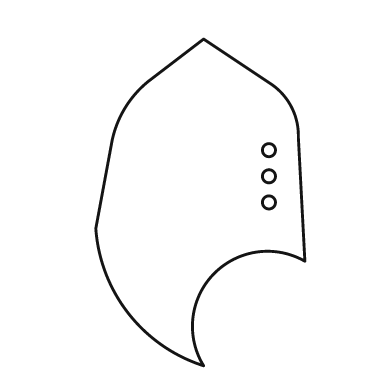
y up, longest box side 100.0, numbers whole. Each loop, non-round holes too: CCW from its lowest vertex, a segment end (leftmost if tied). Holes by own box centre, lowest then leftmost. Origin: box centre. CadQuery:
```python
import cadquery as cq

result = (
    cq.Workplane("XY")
    .moveTo(1.0, -50.0)
    .threePointArc((4.0, -22.0), (32.0, -18.0))
    .lineTo(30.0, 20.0)
    .threePointArc((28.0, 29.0), (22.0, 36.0))
    .lineTo(1.0, 50.0)
    .lineTo(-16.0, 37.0)
    .threePointArc((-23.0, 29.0), (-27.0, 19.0))
    .lineTo(-32.0, -8.0)
    .threePointArc((-22.0, -34.0), (1.0, -50.0))
    .close()
    .moveTo(21.0, 0.0)
    .circle(2.0)
    .moveTo(21.0, 8.0)
    .circle(2.0)
    .moveTo(21.0, 16.0)
    .circle(2.0)
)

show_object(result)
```